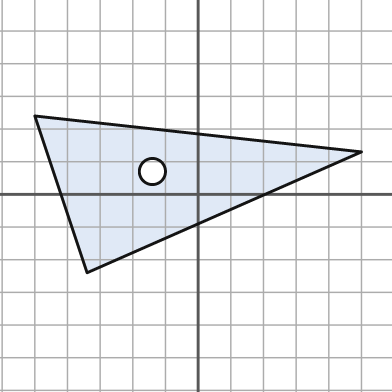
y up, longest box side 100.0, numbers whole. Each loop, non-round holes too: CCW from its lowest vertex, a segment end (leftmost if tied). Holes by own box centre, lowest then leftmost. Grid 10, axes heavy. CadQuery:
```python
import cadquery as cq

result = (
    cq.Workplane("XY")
    .moveTo(-34.0, -24.0)
    .lineTo(50.0, 13.0)
    .lineTo(-50.0, 24.0)
    .close()
    .moveTo(-14.0, 7.0)
    .circle(4.0)
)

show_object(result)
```